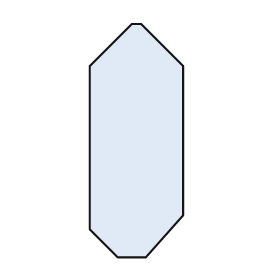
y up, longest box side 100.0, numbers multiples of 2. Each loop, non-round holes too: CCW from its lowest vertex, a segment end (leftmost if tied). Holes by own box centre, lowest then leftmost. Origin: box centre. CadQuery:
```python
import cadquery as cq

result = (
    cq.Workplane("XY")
    .moveTo(-8.0, -50.0)
    .lineTo(4.0, -50.0)
    .lineTo(20.0, -32.0)
    .lineTo(20.0, 32.0)
    .lineTo(2.0, 50.0)
    .lineTo(-2.0, 50.0)
    .lineTo(-20.0, 32.0)
    .lineTo(-20.0, -38.0)
    .close()
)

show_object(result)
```